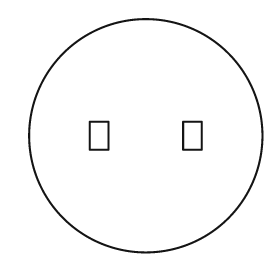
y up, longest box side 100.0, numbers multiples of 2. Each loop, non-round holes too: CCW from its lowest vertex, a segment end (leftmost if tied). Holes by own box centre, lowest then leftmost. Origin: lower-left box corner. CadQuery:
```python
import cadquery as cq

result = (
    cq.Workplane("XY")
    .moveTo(50.0, 50.0)
    .circle(50.0)
    .moveTo(26.0, 44.0)
    .lineTo(34.0, 44.0)
    .lineTo(34.0, 56.0)
    .lineTo(26.0, 56.0)
    .close()
    .moveTo(66.0, 44.0)
    .lineTo(74.0, 44.0)
    .lineTo(74.0, 56.0)
    .lineTo(66.0, 56.0)
    .close()
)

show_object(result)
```